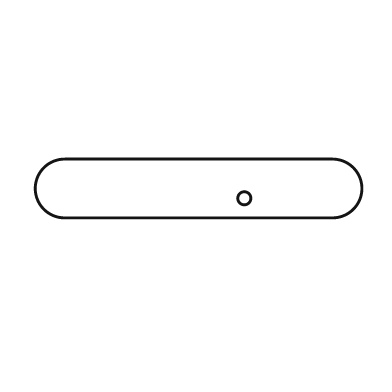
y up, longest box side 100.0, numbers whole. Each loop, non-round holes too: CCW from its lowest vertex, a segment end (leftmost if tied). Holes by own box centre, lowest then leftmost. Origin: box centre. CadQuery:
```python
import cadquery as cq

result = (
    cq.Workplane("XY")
    .moveTo(-41.0, -9.0)
    .lineTo(41.0, -9.0)
    .threePointArc((50.0, 0.0), (41.0, 9.0))
    .lineTo(-41.0, 9.0)
    .threePointArc((-50.0, 0.0), (-41.0, -9.0))
    .close()
    .moveTo(14.0, -3.0)
    .circle(2.0)
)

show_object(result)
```